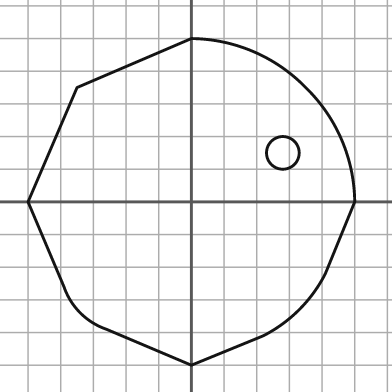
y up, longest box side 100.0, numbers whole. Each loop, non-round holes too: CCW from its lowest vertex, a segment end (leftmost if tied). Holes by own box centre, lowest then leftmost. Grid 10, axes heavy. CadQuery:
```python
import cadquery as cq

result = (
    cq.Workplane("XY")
    .moveTo(0.0, -50.0)
    .lineTo(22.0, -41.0)
    .threePointArc((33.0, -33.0), (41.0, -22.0))
    .lineTo(50.0, 0.0)
    .threePointArc((46.0, 19.0), (35.0, 35.0))
    .threePointArc((19.0, 46.0), (0.0, 50.0))
    .lineTo(-35.0, 35.0)
    .lineTo(-50.0, 0.0)
    .lineTo(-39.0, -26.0)
    .threePointArc((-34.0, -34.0), (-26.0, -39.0))
    .close()
    .moveTo(28.0, 15.0)
    .circle(5.0)
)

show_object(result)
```